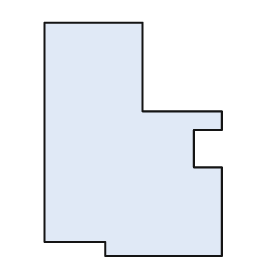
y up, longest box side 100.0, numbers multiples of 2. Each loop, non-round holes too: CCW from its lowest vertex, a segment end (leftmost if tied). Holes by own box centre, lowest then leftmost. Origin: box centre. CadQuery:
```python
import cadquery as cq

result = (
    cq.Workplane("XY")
    .moveTo(-12.0, -50.0)
    .lineTo(38.0, -50.0)
    .lineTo(38.0, -12.0)
    .lineTo(26.0, -12.0)
    .lineTo(26.0, 4.0)
    .lineTo(38.0, 4.0)
    .lineTo(38.0, 12.0)
    .lineTo(4.0, 12.0)
    .lineTo(4.0, 50.0)
    .lineTo(-38.0, 50.0)
    .lineTo(-38.0, -44.0)
    .lineTo(-12.0, -44.0)
    .close()
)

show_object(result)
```